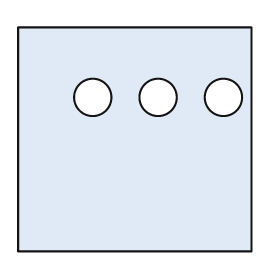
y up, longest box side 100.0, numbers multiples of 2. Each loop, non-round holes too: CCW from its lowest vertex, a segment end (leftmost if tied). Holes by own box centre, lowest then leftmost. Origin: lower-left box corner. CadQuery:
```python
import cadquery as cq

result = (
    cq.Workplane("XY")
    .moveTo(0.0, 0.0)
    .lineTo(100.0, 0.0)
    .lineTo(100.0, 96.0)
    .lineTo(0.0, 96.0)
    .close()
    .moveTo(32.0, 66.0)
    .circle(8.0)
    .moveTo(60.0, 66.0)
    .circle(8.0)
    .moveTo(88.0, 66.0)
    .circle(8.0)
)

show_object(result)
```